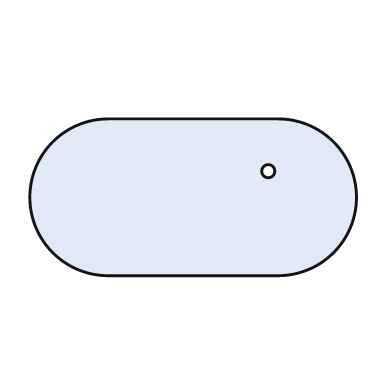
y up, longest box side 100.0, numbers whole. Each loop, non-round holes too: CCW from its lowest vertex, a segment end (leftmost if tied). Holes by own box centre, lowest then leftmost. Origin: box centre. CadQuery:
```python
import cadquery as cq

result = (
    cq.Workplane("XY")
    .moveTo(-26.0, -24.0)
    .lineTo(26.0, -24.0)
    .threePointArc((50.0, 0.0), (26.0, 24.0))
    .lineTo(-26.0, 24.0)
    .threePointArc((-50.0, 0.0), (-26.0, -24.0))
    .close()
    .moveTo(23.0, 8.0)
    .circle(2.0)
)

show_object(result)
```